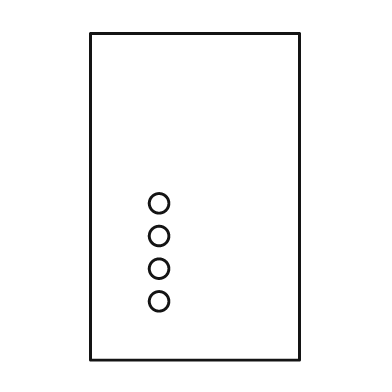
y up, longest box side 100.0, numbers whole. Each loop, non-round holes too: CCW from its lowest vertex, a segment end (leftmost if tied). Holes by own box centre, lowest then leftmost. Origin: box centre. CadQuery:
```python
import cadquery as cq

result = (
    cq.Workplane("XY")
    .moveTo(-32.0, -50.0)
    .lineTo(32.0, -50.0)
    .lineTo(32.0, 50.0)
    .lineTo(-32.0, 50.0)
    .close()
    .moveTo(-11.0, -32.0)
    .circle(3.0)
    .moveTo(-11.0, -22.0)
    .circle(3.0)
    .moveTo(-11.0, -12.0)
    .circle(3.0)
    .moveTo(-11.0, -2.0)
    .circle(3.0)
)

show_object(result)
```